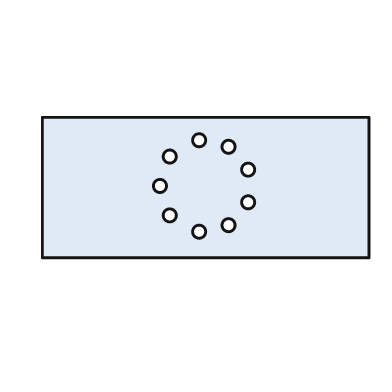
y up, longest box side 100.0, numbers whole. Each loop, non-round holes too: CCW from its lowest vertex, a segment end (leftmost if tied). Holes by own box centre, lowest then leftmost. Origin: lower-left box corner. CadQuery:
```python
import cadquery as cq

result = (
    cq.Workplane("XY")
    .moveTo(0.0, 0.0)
    .lineTo(100.0, 0.0)
    .lineTo(100.0, 43.0)
    .lineTo(0.0, 43.0)
    .close()
    .moveTo(48.0, 8.0)
    .circle(2.0)
    .moveTo(57.0, 10.0)
    .circle(2.0)
    .moveTo(39.0, 13.0)
    .circle(2.0)
    .moveTo(63.0, 17.0)
    .circle(2.0)
    .moveTo(36.0, 22.0)
    .circle(2.0)
    .moveTo(63.0, 27.0)
    .circle(2.0)
    .moveTo(39.0, 31.0)
    .circle(2.0)
    .moveTo(57.0, 34.0)
    .circle(2.0)
    .moveTo(48.0, 36.0)
    .circle(2.0)
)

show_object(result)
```